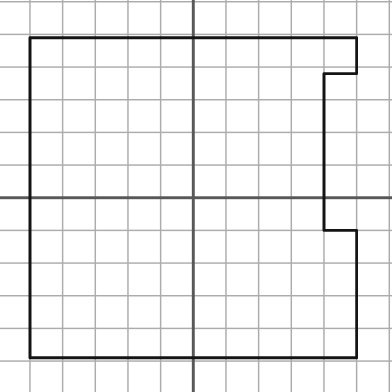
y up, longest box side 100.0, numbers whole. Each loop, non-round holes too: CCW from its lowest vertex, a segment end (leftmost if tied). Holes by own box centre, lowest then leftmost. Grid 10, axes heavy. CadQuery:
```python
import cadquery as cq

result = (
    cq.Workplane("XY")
    .moveTo(-50.0, -49.0)
    .lineTo(50.0, -49.0)
    .lineTo(50.0, -10.0)
    .lineTo(40.0, -10.0)
    .lineTo(40.0, 38.0)
    .lineTo(50.0, 38.0)
    .lineTo(50.0, 49.0)
    .lineTo(-50.0, 49.0)
    .close()
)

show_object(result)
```